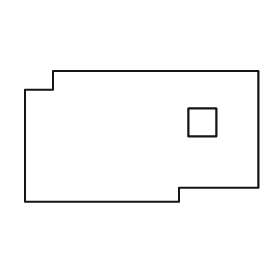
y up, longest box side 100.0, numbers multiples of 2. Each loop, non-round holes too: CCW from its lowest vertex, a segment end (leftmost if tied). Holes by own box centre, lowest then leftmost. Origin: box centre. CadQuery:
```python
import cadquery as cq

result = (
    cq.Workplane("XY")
    .moveTo(-50.0, -28.0)
    .lineTo(16.0, -28.0)
    .lineTo(16.0, -22.0)
    .lineTo(50.0, -22.0)
    .lineTo(50.0, 28.0)
    .lineTo(-38.0, 28.0)
    .lineTo(-38.0, 20.0)
    .lineTo(-50.0, 20.0)
    .close()
    .moveTo(20.0, 0.0)
    .lineTo(32.0, 0.0)
    .lineTo(32.0, 12.0)
    .lineTo(20.0, 12.0)
    .close()
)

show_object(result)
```